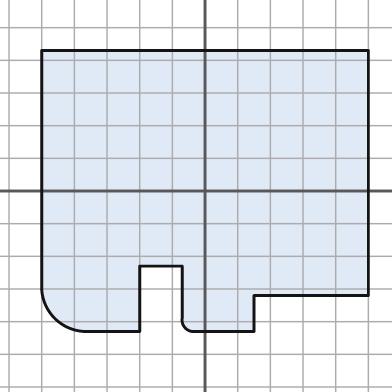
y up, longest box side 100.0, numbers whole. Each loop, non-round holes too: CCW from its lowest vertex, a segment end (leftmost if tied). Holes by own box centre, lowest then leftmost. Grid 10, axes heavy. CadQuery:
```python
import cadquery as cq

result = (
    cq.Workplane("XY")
    .moveTo(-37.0, -43.0)
    .lineTo(-20.0, -43.0)
    .lineTo(-20.0, -23.0)
    .lineTo(-7.0, -23.0)
    .lineTo(-7.0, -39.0)
    .threePointArc((-6.0, -42.0), (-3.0, -43.0))
    .lineTo(15.0, -43.0)
    .lineTo(15.0, -32.0)
    .lineTo(50.0, -32.0)
    .lineTo(50.0, 43.0)
    .lineTo(-50.0, 43.0)
    .lineTo(-50.0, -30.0)
    .threePointArc((-46.0, -39.0), (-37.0, -43.0))
    .close()
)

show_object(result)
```